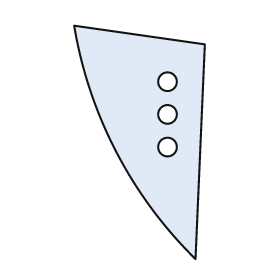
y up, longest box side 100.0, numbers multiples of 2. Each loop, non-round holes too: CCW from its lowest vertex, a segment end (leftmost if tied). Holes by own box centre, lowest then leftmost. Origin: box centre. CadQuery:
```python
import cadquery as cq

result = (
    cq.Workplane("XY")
    .moveTo(24.0, -50.0)
    .lineTo(28.0, 42.0)
    .lineTo(-28.0, 50.0)
    .threePointArc((-10.0, -4.0), (24.0, -50.0))
    .close()
    .moveTo(12.0, -2.0)
    .circle(4.0)
    .moveTo(12.0, 12.0)
    .circle(4.0)
    .moveTo(12.0, 26.0)
    .circle(4.0)
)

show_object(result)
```